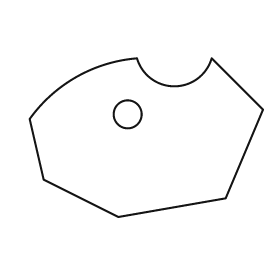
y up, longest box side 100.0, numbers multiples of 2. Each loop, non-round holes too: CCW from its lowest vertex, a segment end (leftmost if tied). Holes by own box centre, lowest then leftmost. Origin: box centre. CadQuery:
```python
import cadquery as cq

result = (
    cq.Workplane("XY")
    .moveTo(-12.0, -34.0)
    .lineTo(34.0, -26.0)
    .lineTo(50.0, 12.0)
    .lineTo(28.0, 34.0)
    .threePointArc((12.0, 22.0), (-4.0, 34.0))
    .threePointArc((-30.0, 26.0), (-50.0, 8.0))
    .lineTo(-44.0, -18.0)
    .close()
    .moveTo(-8.0, 10.0)
    .circle(6.0)
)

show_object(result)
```